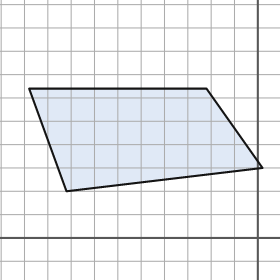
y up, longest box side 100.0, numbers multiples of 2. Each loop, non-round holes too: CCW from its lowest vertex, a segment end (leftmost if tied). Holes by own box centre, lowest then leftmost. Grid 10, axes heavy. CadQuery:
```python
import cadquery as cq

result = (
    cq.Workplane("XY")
    .moveTo(-82.0, 20.0)
    .lineTo(2.0, 30.0)
    .lineTo(-22.0, 64.0)
    .lineTo(-98.0, 64.0)
    .close()
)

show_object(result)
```